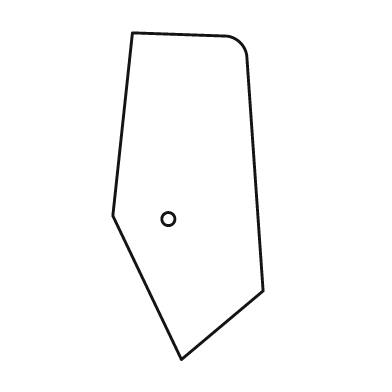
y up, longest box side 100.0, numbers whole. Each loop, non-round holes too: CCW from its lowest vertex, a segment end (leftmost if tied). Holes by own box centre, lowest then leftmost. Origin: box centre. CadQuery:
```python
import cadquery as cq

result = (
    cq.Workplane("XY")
    .moveTo(-2.0, -50.0)
    .lineTo(23.0, -29.0)
    .lineTo(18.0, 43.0)
    .threePointArc((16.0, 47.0), (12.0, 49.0))
    .lineTo(-17.0, 50.0)
    .lineTo(-23.0, -6.0)
    .close()
    .moveTo(-6.0, -7.0)
    .circle(2.0)
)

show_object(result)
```